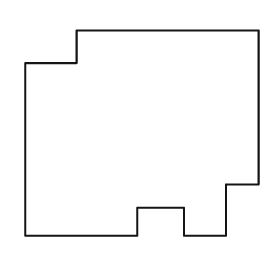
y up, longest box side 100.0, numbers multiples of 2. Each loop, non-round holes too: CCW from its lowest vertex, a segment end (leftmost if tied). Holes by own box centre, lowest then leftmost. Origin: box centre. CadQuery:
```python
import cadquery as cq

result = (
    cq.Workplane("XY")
    .moveTo(-50.0, -44.0)
    .lineTo(-2.0, -44.0)
    .lineTo(-2.0, -32.0)
    .lineTo(18.0, -32.0)
    .lineTo(18.0, -44.0)
    .lineTo(36.0, -44.0)
    .lineTo(36.0, -22.0)
    .lineTo(50.0, -22.0)
    .lineTo(50.0, 44.0)
    .lineTo(-28.0, 44.0)
    .lineTo(-28.0, 30.0)
    .lineTo(-50.0, 30.0)
    .close()
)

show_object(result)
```